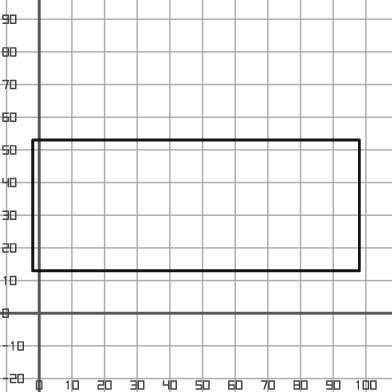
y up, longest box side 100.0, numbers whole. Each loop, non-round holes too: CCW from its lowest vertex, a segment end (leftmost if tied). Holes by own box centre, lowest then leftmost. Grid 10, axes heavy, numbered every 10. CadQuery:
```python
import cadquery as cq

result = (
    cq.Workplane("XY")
    .moveTo(-2.0, 13.0)
    .lineTo(98.0, 13.0)
    .lineTo(98.0, 53.0)
    .lineTo(-2.0, 53.0)
    .close()
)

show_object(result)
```